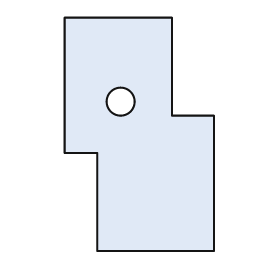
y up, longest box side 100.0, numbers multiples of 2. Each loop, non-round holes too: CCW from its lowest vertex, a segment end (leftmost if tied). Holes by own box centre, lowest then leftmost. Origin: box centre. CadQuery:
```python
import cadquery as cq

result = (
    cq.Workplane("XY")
    .moveTo(-18.0, -50.0)
    .lineTo(32.0, -50.0)
    .lineTo(32.0, 8.0)
    .lineTo(14.0, 8.0)
    .lineTo(14.0, 50.0)
    .lineTo(-32.0, 50.0)
    .lineTo(-32.0, -8.0)
    .lineTo(-18.0, -8.0)
    .close()
    .moveTo(-8.0, 14.0)
    .circle(6.0)
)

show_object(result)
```